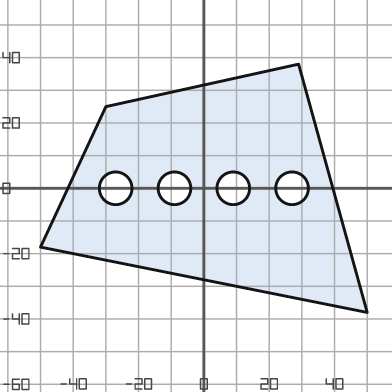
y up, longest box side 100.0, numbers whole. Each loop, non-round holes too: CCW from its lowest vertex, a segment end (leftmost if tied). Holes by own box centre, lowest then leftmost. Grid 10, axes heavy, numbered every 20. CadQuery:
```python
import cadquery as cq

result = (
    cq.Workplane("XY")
    .moveTo(50.0, -38.0)
    .lineTo(29.0, 38.0)
    .lineTo(-30.0, 25.0)
    .lineTo(-50.0, -18.0)
    .close()
    .moveTo(-27.0, 0.0)
    .circle(5.0)
    .moveTo(-9.0, 0.0)
    .circle(5.0)
    .moveTo(9.0, 0.0)
    .circle(5.0)
    .moveTo(27.0, 0.0)
    .circle(5.0)
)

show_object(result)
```